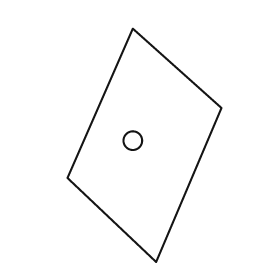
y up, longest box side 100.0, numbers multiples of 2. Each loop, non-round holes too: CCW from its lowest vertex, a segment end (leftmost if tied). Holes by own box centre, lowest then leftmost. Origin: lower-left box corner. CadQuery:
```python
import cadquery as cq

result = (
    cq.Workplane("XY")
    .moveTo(38.0, 0.0)
    .lineTo(66.0, 66.0)
    .lineTo(28.0, 100.0)
    .lineTo(0.0, 36.0)
    .close()
    .moveTo(28.0, 52.0)
    .circle(4.0)
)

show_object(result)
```